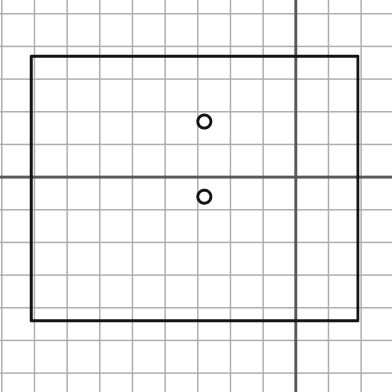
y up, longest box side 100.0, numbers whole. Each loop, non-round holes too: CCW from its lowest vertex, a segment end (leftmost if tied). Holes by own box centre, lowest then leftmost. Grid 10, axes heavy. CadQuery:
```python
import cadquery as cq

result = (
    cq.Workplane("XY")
    .moveTo(-81.0, -44.0)
    .lineTo(19.0, -44.0)
    .lineTo(19.0, 37.0)
    .lineTo(-81.0, 37.0)
    .close()
    .moveTo(-28.0, -6.0)
    .circle(2.0)
    .moveTo(-28.0, 17.0)
    .circle(2.0)
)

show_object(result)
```